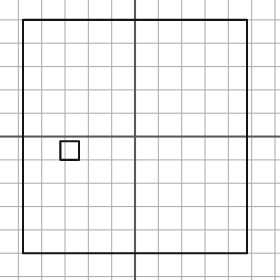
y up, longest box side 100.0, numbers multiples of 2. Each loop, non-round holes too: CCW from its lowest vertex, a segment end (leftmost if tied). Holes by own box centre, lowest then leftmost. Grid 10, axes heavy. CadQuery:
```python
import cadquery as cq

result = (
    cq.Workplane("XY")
    .moveTo(-48.0, -50.0)
    .lineTo(48.0, -50.0)
    .lineTo(48.0, 50.0)
    .lineTo(-48.0, 50.0)
    .close()
    .moveTo(-32.0, -10.0)
    .lineTo(-24.0, -10.0)
    .lineTo(-24.0, -2.0)
    .lineTo(-32.0, -2.0)
    .close()
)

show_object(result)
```